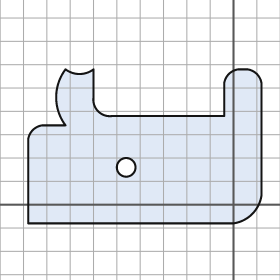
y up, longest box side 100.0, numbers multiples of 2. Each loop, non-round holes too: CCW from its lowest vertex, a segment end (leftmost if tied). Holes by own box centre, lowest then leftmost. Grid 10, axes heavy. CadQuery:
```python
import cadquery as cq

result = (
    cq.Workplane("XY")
    .moveTo(-88.0, -8.0)
    .lineTo(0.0, -8.0)
    .threePointArc((8.0, -4.0), (12.0, 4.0))
    .lineTo(12.0, 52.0)
    .threePointArc((10.0, 56.0), (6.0, 58.0))
    .lineTo(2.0, 58.0)
    .threePointArc((-2.0, 56.0), (-4.0, 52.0))
    .lineTo(-4.0, 38.0)
    .lineTo(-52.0, 38.0)
    .threePointArc((-58.0, 40.0), (-60.0, 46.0))
    .lineTo(-60.0, 58.0)
    .threePointArc((-66.0, 56.0), (-72.0, 58.0))
    .threePointArc((-76.0, 46.0), (-72.0, 34.0))
    .lineTo(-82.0, 34.0)
    .threePointArc((-86.0, 32.0), (-88.0, 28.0))
    .close()
    .moveTo(-46.0, 16.0)
    .circle(4.0)
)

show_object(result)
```